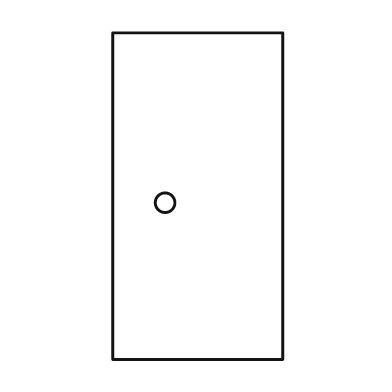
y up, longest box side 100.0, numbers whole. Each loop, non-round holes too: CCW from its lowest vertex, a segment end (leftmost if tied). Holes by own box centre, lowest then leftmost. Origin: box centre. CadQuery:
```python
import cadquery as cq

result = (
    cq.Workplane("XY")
    .moveTo(-26.0, -50.0)
    .lineTo(26.0, -50.0)
    .lineTo(26.0, 50.0)
    .lineTo(-26.0, 50.0)
    .close()
    .moveTo(-10.0, -2.0)
    .circle(3.0)
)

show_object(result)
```